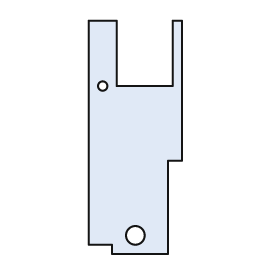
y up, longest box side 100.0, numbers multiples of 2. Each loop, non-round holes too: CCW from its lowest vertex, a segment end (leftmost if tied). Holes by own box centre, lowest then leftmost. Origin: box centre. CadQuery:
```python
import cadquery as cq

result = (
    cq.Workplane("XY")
    .moveTo(-10.0, -50.0)
    .lineTo(14.0, -50.0)
    .lineTo(14.0, -10.0)
    .lineTo(20.0, -10.0)
    .lineTo(20.0, 50.0)
    .lineTo(16.0, 50.0)
    .lineTo(16.0, 22.0)
    .lineTo(-8.0, 22.0)
    .lineTo(-8.0, 50.0)
    .lineTo(-20.0, 50.0)
    .lineTo(-20.0, -46.0)
    .lineTo(-10.0, -46.0)
    .close()
    .moveTo(0.0, -42.0)
    .circle(4.0)
    .moveTo(-14.0, 22.0)
    .circle(2.0)
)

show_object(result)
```